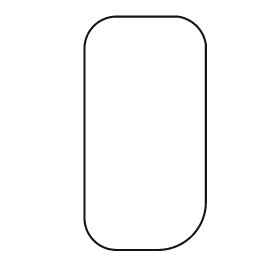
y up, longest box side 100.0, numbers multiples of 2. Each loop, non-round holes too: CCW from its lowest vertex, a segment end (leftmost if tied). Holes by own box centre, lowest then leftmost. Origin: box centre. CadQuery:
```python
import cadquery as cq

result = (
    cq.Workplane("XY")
    .moveTo(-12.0, -50.0)
    .lineTo(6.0, -50.0)
    .threePointArc((20.0, -44.0), (26.0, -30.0))
    .lineTo(26.0, 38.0)
    .threePointArc((22.0, 46.0), (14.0, 50.0))
    .lineTo(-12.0, 50.0)
    .threePointArc((-22.0, 46.0), (-26.0, 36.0))
    .lineTo(-26.0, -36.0)
    .threePointArc((-22.0, -46.0), (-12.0, -50.0))
    .close()
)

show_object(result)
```